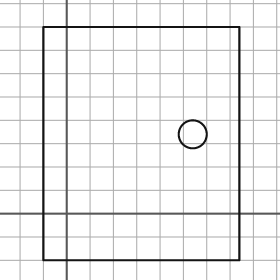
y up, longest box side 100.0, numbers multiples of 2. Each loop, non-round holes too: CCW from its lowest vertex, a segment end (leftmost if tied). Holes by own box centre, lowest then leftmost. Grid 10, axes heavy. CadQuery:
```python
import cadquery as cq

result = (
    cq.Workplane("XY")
    .moveTo(-10.0, -20.0)
    .lineTo(74.0, -20.0)
    .lineTo(74.0, 80.0)
    .lineTo(-10.0, 80.0)
    .close()
    .moveTo(54.0, 34.0)
    .circle(6.0)
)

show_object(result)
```